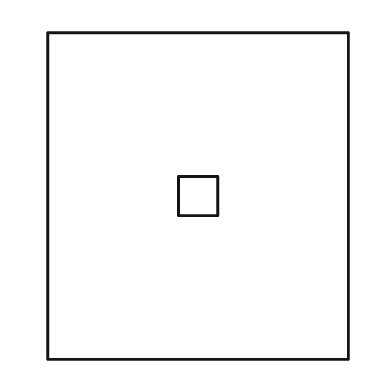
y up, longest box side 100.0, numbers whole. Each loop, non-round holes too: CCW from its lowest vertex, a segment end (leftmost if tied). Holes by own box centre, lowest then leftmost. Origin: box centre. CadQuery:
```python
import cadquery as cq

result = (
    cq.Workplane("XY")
    .moveTo(-46.0, -50.0)
    .lineTo(46.0, -50.0)
    .lineTo(46.0, 50.0)
    .lineTo(-46.0, 50.0)
    .close()
    .moveTo(-6.0, -6.0)
    .lineTo(6.0, -6.0)
    .lineTo(6.0, 6.0)
    .lineTo(-6.0, 6.0)
    .close()
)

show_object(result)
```